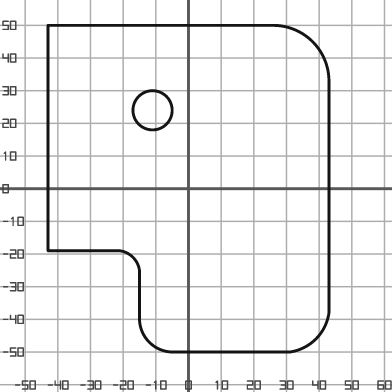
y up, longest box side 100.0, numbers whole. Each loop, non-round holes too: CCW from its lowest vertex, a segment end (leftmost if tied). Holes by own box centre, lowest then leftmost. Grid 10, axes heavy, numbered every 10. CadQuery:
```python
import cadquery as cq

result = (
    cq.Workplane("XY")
    .moveTo(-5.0, -50.0)
    .lineTo(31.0, -50.0)
    .threePointArc((39.0, -46.0), (43.0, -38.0))
    .lineTo(43.0, 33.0)
    .threePointArc((38.0, 45.0), (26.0, 50.0))
    .lineTo(-43.0, 50.0)
    .lineTo(-43.0, -19.0)
    .lineTo(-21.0, -19.0)
    .threePointArc((-17.0, -21.0), (-15.0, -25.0))
    .lineTo(-15.0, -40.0)
    .threePointArc((-12.0, -47.0), (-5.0, -50.0))
    .close()
    .moveTo(-11.0, 24.0)
    .circle(6.0)
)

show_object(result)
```